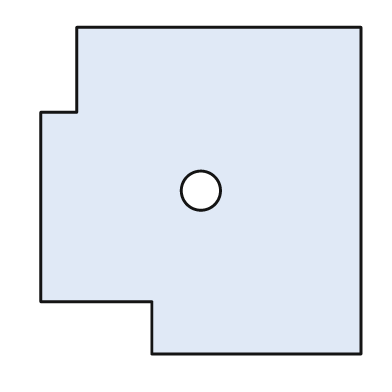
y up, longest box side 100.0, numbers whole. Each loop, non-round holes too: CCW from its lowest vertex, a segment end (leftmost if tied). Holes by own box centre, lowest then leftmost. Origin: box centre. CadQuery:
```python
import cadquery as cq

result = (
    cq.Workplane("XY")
    .moveTo(-15.0, -50.0)
    .lineTo(49.0, -50.0)
    .lineTo(49.0, 50.0)
    .lineTo(-38.0, 50.0)
    .lineTo(-38.0, 24.0)
    .lineTo(-49.0, 24.0)
    .lineTo(-49.0, -34.0)
    .lineTo(-15.0, -34.0)
    .close()
    .moveTo(0.0, 0.0)
    .circle(6.0)
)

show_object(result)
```